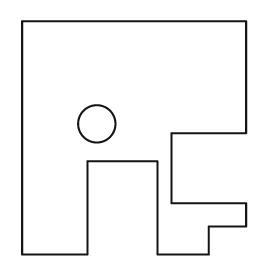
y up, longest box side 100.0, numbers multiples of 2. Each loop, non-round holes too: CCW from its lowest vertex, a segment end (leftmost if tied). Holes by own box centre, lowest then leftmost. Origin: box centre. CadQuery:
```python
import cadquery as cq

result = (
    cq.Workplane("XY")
    .moveTo(-48.0, -50.0)
    .lineTo(-20.0, -50.0)
    .lineTo(-20.0, -10.0)
    .lineTo(10.0, -10.0)
    .lineTo(10.0, -50.0)
    .lineTo(32.0, -50.0)
    .lineTo(32.0, -38.0)
    .lineTo(48.0, -38.0)
    .lineTo(48.0, -28.0)
    .lineTo(16.0, -28.0)
    .lineTo(16.0, 2.0)
    .lineTo(48.0, 2.0)
    .lineTo(48.0, 50.0)
    .lineTo(-48.0, 50.0)
    .close()
    .moveTo(-16.0, 6.0)
    .circle(8.0)
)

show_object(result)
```